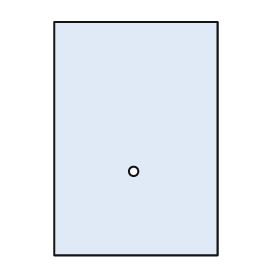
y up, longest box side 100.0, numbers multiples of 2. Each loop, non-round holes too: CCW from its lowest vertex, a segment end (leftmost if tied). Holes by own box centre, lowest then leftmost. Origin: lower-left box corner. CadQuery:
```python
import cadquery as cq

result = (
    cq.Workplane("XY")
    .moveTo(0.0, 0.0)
    .lineTo(70.0, 0.0)
    .lineTo(70.0, 100.0)
    .lineTo(0.0, 100.0)
    .close()
    .moveTo(34.0, 36.0)
    .circle(2.0)
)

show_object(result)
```